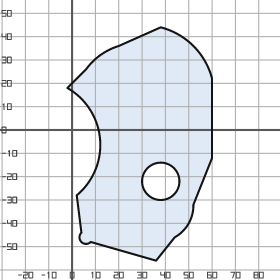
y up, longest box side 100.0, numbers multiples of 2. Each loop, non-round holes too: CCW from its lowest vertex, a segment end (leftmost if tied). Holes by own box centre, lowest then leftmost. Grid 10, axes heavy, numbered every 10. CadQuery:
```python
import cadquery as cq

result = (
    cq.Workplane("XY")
    .moveTo(36.0, -56.0)
    .lineTo(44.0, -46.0)
    .threePointArc((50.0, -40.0), (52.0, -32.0))
    .lineTo(60.0, -12.0)
    .lineTo(60.0, 22.0)
    .threePointArc((52.0, 36.0), (38.0, 44.0))
    .lineTo(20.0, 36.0)
    .threePointArc((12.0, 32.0), (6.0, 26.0))
    .lineTo(-2.0, 18.0)
    .threePointArc((12.0, -4.0), (2.0, -28.0))
    .lineTo(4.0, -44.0)
    .threePointArc((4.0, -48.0), (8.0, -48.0))
    .close()
    .moveTo(38.0, -22.0)
    .circle(8.0)
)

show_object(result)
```